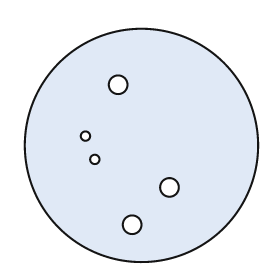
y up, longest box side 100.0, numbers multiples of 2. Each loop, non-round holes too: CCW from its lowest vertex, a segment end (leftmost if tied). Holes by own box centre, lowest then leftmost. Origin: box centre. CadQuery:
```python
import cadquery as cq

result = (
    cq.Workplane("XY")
    .moveTo(0.0, 0.0)
    .circle(50.0)
    .moveTo(-4.0, -34.0)
    .circle(4.0)
    .moveTo(12.0, -18.0)
    .circle(4.0)
    .moveTo(-20.0, -6.0)
    .circle(2.0)
    .moveTo(-24.0, 4.0)
    .circle(2.0)
    .moveTo(-10.0, 26.0)
    .circle(4.0)
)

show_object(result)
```